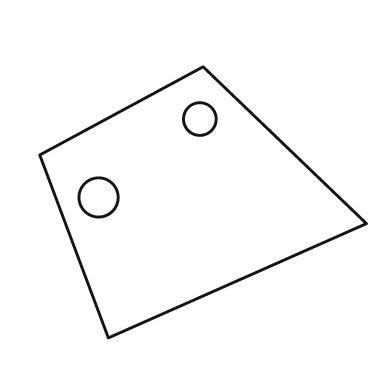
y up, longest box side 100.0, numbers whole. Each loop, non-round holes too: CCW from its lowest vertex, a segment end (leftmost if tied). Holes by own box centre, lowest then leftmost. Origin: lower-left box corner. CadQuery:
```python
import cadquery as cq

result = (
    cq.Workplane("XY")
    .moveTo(21.0, 0.0)
    .lineTo(100.0, 35.0)
    .lineTo(50.0, 83.0)
    .lineTo(0.0, 56.0)
    .close()
    .moveTo(18.0, 43.0)
    .circle(6.0)
    .moveTo(49.0, 67.0)
    .circle(5.0)
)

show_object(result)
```